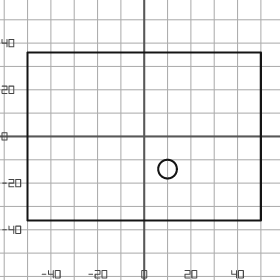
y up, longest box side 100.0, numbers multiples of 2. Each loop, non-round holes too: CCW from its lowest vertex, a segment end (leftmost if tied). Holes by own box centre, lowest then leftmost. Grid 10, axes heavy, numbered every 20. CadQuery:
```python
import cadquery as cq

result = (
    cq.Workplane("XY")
    .moveTo(-50.0, -36.0)
    .lineTo(50.0, -36.0)
    .lineTo(50.0, 36.0)
    .lineTo(-50.0, 36.0)
    .close()
    .moveTo(10.0, -14.0)
    .circle(4.0)
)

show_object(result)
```